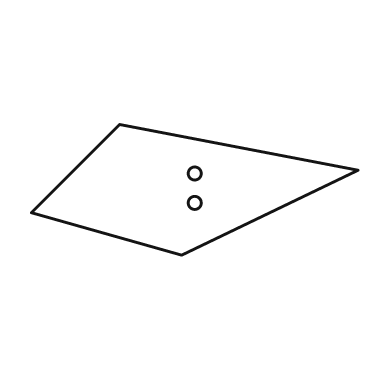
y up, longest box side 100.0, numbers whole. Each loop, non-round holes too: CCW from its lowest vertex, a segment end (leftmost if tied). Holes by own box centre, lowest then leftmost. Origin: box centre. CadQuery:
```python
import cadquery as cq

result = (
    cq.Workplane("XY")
    .moveTo(-4.0, -20.0)
    .lineTo(50.0, 6.0)
    .lineTo(-23.0, 20.0)
    .lineTo(-50.0, -7.0)
    .close()
    .moveTo(0.0, -4.0)
    .circle(2.0)
    .moveTo(0.0, 5.0)
    .circle(2.0)
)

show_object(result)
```